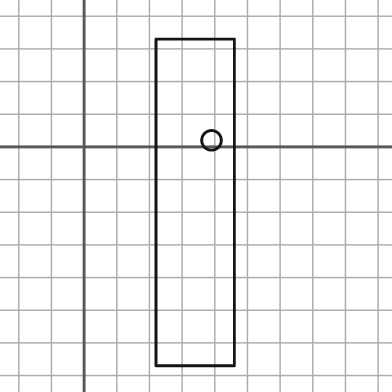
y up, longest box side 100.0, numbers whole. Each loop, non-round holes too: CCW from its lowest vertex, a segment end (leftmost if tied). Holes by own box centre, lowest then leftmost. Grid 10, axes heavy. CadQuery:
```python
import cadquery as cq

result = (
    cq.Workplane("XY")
    .moveTo(22.0, -67.0)
    .lineTo(46.0, -67.0)
    .lineTo(46.0, 33.0)
    .lineTo(22.0, 33.0)
    .close()
    .moveTo(39.0, 2.0)
    .circle(3.0)
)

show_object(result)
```